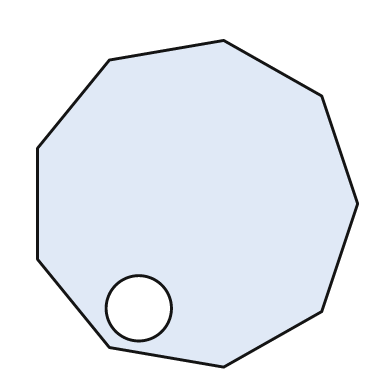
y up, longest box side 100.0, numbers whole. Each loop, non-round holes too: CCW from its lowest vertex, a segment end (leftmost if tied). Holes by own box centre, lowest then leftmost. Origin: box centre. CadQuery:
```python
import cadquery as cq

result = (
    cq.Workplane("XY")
    .moveTo(8.0, -50.0)
    .lineTo(38.0, -33.0)
    .lineTo(49.0, 0.0)
    .lineTo(38.0, 33.0)
    .lineTo(8.0, 50.0)
    .lineTo(-27.0, 44.0)
    .lineTo(-49.0, 17.0)
    .lineTo(-49.0, -17.0)
    .lineTo(-27.0, -44.0)
    .close()
    .moveTo(-18.0, -32.0)
    .circle(10.0)
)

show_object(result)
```